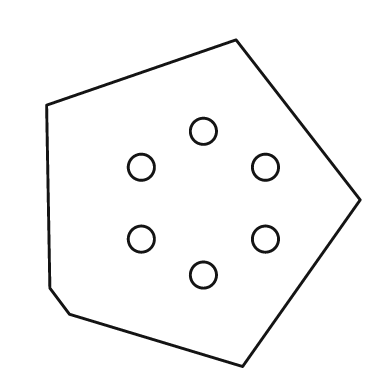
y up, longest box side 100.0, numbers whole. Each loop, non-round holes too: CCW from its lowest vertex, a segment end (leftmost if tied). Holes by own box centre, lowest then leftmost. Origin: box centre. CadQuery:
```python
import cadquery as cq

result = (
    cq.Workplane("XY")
    .moveTo(12.0, -50.0)
    .lineTo(48.0, 1.0)
    .lineTo(10.0, 50.0)
    .lineTo(-48.0, 30.0)
    .lineTo(-47.0, -26.0)
    .lineTo(-41.0, -34.0)
    .close()
    .moveTo(0.0, -22.0)
    .circle(4.0)
    .moveTo(-19.0, -11.0)
    .circle(4.0)
    .moveTo(19.0, -11.0)
    .circle(4.0)
    .moveTo(-19.0, 11.0)
    .circle(4.0)
    .moveTo(19.0, 11.0)
    .circle(4.0)
    .moveTo(0.0, 22.0)
    .circle(4.0)
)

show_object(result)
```